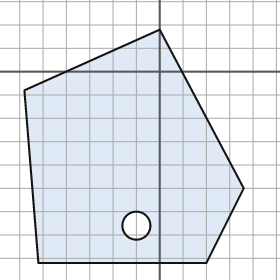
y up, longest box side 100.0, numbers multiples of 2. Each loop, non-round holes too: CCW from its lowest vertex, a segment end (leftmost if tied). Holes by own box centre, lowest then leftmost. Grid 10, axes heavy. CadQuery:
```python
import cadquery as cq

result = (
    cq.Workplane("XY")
    .moveTo(-52.0, -82.0)
    .lineTo(20.0, -82.0)
    .lineTo(36.0, -50.0)
    .lineTo(0.0, 18.0)
    .lineTo(-58.0, -8.0)
    .close()
    .moveTo(-10.0, -66.0)
    .circle(6.0)
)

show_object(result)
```